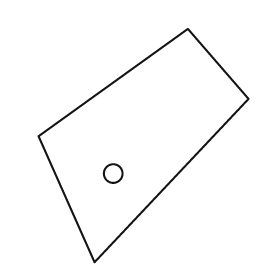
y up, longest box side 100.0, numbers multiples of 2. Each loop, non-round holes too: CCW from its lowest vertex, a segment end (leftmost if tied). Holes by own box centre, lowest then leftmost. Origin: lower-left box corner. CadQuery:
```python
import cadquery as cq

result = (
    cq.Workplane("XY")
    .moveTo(24.0, 0.0)
    .lineTo(90.0, 70.0)
    .lineTo(64.0, 100.0)
    .lineTo(0.0, 54.0)
    .close()
    .moveTo(32.0, 38.0)
    .circle(4.0)
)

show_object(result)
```